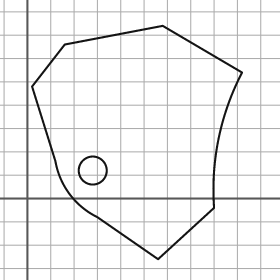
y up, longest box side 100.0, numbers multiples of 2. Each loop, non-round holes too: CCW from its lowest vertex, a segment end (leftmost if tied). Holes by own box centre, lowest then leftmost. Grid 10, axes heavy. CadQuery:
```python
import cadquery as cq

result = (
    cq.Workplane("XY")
    .moveTo(56.0, -26.0)
    .lineTo(80.0, -4.0)
    .threePointArc((82.0, 26.0), (92.0, 54.0))
    .lineTo(58.0, 74.0)
    .lineTo(16.0, 66.0)
    .lineTo(2.0, 48.0)
    .lineTo(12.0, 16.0)
    .threePointArc((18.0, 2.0), (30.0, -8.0))
    .close()
    .moveTo(28.0, 12.0)
    .circle(6.0)
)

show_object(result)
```